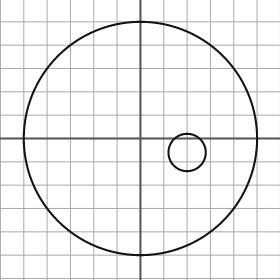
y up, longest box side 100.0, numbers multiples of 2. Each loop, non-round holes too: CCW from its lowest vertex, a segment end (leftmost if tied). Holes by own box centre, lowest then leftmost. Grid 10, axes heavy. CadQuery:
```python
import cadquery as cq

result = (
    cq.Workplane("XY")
    .moveTo(0.0, 0.0)
    .circle(50.0)
    .moveTo(20.0, -6.0)
    .circle(8.0)
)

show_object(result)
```